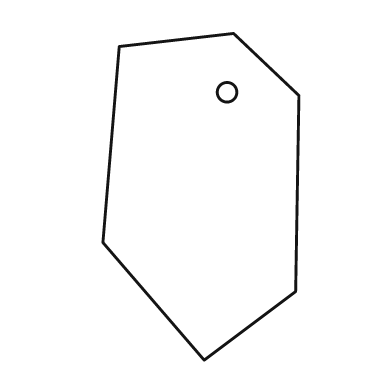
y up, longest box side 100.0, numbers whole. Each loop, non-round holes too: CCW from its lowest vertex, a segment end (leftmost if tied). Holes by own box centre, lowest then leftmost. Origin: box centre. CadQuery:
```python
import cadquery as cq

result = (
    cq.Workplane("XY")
    .moveTo(1.0, -50.0)
    .lineTo(29.0, -29.0)
    .lineTo(30.0, 31.0)
    .lineTo(10.0, 50.0)
    .lineTo(-25.0, 46.0)
    .lineTo(-30.0, -14.0)
    .close()
    .moveTo(8.0, 32.0)
    .circle(3.0)
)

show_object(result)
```